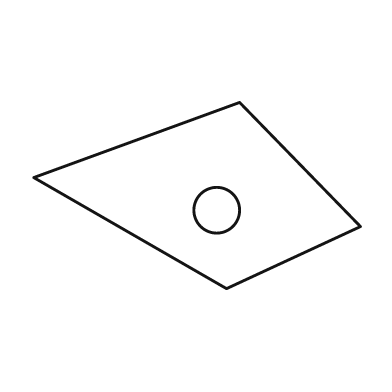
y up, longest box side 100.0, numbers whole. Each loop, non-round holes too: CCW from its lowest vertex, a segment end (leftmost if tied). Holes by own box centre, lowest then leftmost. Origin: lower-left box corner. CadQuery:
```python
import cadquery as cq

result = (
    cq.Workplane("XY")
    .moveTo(59.0, 0.0)
    .lineTo(100.0, 19.0)
    .lineTo(63.0, 57.0)
    .lineTo(0.0, 34.0)
    .close()
    .moveTo(56.0, 24.0)
    .circle(7.0)
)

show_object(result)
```